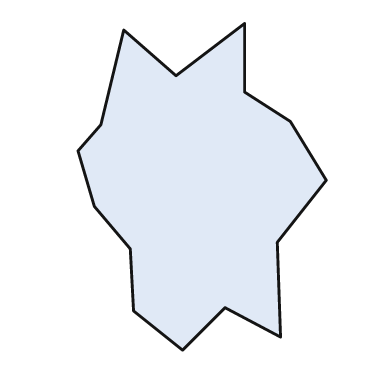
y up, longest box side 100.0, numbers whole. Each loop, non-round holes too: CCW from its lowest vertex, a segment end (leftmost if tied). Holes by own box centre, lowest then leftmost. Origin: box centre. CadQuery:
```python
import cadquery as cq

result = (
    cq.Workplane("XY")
    .moveTo(-6.0, -50.0)
    .lineTo(7.0, -37.0)
    .lineTo(24.0, -46.0)
    .lineTo(23.0, -17.0)
    .lineTo(38.0, 2.0)
    .lineTo(27.0, 20.0)
    .lineTo(13.0, 29.0)
    .lineTo(13.0, 50.0)
    .lineTo(-8.0, 34.0)
    .lineTo(-24.0, 48.0)
    .lineTo(-31.0, 19.0)
    .lineTo(-38.0, 11.0)
    .lineTo(-33.0, -6.0)
    .lineTo(-22.0, -19.0)
    .lineTo(-21.0, -38.0)
    .close()
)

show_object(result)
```